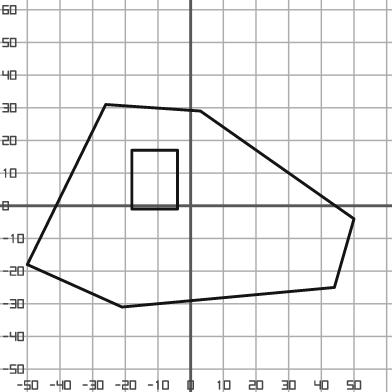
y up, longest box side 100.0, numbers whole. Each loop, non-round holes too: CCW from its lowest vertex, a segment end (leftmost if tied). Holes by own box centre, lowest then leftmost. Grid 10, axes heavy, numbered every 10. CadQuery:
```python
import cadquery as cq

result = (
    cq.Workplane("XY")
    .moveTo(-21.0, -31.0)
    .lineTo(44.0, -25.0)
    .lineTo(50.0, -4.0)
    .lineTo(3.0, 29.0)
    .lineTo(-26.0, 31.0)
    .lineTo(-50.0, -18.0)
    .close()
    .moveTo(-18.0, -1.0)
    .lineTo(-4.0, -1.0)
    .lineTo(-4.0, 17.0)
    .lineTo(-18.0, 17.0)
    .close()
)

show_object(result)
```